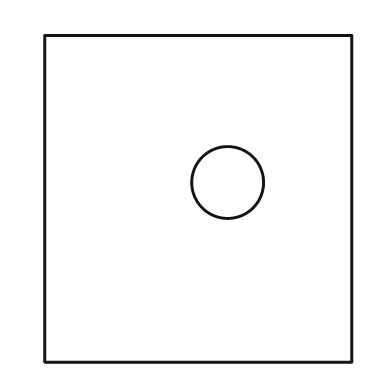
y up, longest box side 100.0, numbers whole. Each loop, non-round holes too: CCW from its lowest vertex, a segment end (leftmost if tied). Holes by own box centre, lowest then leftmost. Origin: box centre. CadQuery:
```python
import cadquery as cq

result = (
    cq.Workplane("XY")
    .moveTo(-47.0, -50.0)
    .lineTo(47.0, -50.0)
    .lineTo(47.0, 50.0)
    .lineTo(-47.0, 50.0)
    .close()
    .moveTo(9.0, 5.0)
    .circle(11.0)
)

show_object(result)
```